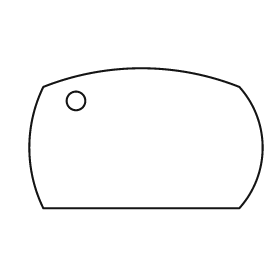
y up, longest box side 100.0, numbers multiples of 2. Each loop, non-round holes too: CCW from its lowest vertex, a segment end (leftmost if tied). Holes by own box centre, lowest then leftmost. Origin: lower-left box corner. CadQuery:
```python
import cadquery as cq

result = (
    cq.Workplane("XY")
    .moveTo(6.0, 0.0)
    .lineTo(90.0, 0.0)
    .threePointArc((100.0, 26.0), (90.0, 52.0))
    .threePointArc((48.0, 60.0), (6.0, 52.0))
    .threePointArc((0.0, 26.0), (6.0, 0.0))
    .close()
    .moveTo(20.0, 46.0)
    .circle(4.0)
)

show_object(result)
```